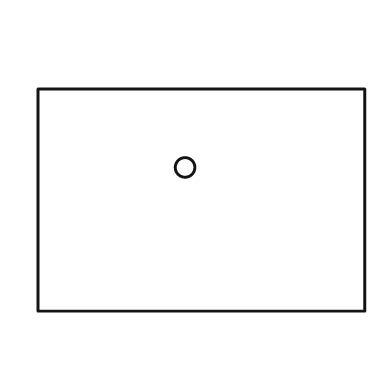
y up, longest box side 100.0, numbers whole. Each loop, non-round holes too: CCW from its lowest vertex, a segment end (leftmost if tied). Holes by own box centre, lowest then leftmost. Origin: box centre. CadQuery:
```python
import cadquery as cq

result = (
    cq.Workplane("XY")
    .moveTo(-50.0, -34.0)
    .lineTo(50.0, -34.0)
    .lineTo(50.0, 34.0)
    .lineTo(-50.0, 34.0)
    .close()
    .moveTo(-5.0, 10.0)
    .circle(3.0)
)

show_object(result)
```